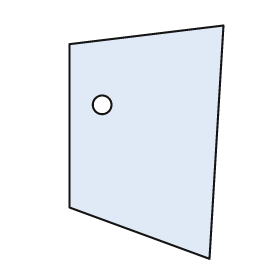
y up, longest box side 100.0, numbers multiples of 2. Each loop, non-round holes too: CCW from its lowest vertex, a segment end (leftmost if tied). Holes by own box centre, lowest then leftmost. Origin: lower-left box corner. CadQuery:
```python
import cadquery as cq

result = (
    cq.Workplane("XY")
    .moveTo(60.0, 0.0)
    .lineTo(66.0, 100.0)
    .lineTo(0.0, 92.0)
    .lineTo(0.0, 22.0)
    .close()
    .moveTo(14.0, 66.0)
    .circle(4.0)
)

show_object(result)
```